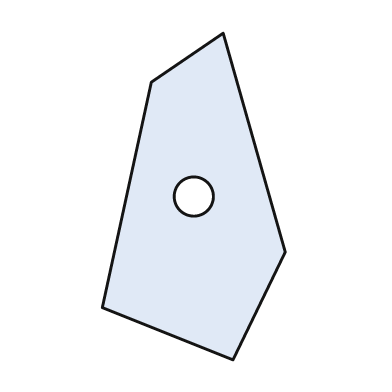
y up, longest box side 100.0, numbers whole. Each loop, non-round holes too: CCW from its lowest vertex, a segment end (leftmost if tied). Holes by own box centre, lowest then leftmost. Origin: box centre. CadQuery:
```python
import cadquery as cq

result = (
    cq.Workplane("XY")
    .moveTo(12.0, -50.0)
    .lineTo(28.0, -17.0)
    .lineTo(9.0, 50.0)
    .lineTo(-13.0, 35.0)
    .lineTo(-28.0, -34.0)
    .close()
    .moveTo(0.0, 0.0)
    .circle(6.0)
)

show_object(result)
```